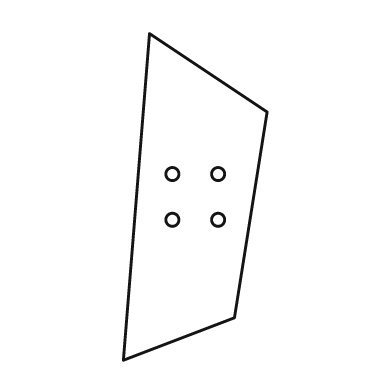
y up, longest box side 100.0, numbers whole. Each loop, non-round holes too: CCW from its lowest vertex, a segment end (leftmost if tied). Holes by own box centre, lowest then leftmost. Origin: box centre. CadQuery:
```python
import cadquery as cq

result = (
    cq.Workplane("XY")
    .moveTo(-22.0, -50.0)
    .lineTo(12.0, -37.0)
    .lineTo(22.0, 26.0)
    .lineTo(-14.0, 50.0)
    .close()
    .moveTo(-7.0, -7.0)
    .circle(2.0)
    .moveTo(7.0, -7.0)
    .circle(2.0)
    .moveTo(-7.0, 7.0)
    .circle(2.0)
    .moveTo(7.0, 7.0)
    .circle(2.0)
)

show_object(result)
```